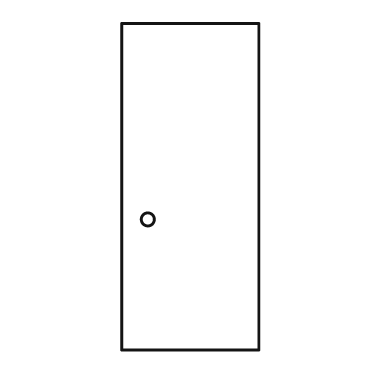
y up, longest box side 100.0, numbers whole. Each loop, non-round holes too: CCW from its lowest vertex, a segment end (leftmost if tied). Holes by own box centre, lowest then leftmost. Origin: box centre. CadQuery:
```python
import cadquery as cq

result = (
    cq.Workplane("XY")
    .moveTo(-21.0, -50.0)
    .lineTo(21.0, -50.0)
    .lineTo(21.0, 50.0)
    .lineTo(-21.0, 50.0)
    .close()
    .moveTo(-13.0, -10.0)
    .circle(2.0)
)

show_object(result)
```